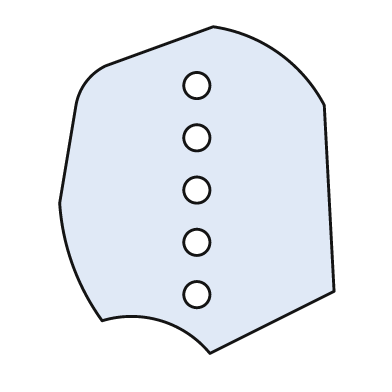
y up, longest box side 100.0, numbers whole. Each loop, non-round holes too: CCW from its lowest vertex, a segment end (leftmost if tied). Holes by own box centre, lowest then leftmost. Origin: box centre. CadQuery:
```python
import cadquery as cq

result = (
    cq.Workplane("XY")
    .moveTo(4.0, -50.0)
    .lineTo(42.0, -31.0)
    .lineTo(39.0, 26.0)
    .threePointArc((25.0, 42.0), (5.0, 50.0))
    .lineTo(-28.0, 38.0)
    .threePointArc((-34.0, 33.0), (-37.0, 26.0))
    .lineTo(-42.0, -4.0)
    .threePointArc((-38.0, -23.0), (-29.0, -40.0))
    .threePointArc((-11.0, -40.0), (4.0, -50.0))
    .close()
    .moveTo(0.0, -32.0)
    .circle(4.0)
    .moveTo(0.0, -16.0)
    .circle(4.0)
    .moveTo(0.0, 0.0)
    .circle(4.0)
    .moveTo(0.0, 16.0)
    .circle(4.0)
    .moveTo(0.0, 32.0)
    .circle(4.0)
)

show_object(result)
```